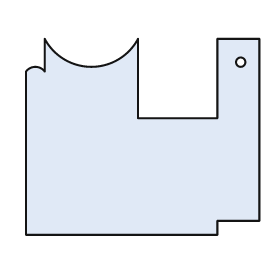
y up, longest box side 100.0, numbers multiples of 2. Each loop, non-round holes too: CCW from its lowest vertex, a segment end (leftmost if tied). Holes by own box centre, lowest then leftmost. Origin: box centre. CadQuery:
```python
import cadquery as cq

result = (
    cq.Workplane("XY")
    .moveTo(-50.0, -42.0)
    .lineTo(32.0, -42.0)
    .lineTo(32.0, -36.0)
    .lineTo(50.0, -36.0)
    .lineTo(50.0, 42.0)
    .lineTo(32.0, 42.0)
    .lineTo(32.0, 8.0)
    .lineTo(-2.0, 8.0)
    .lineTo(-2.0, 42.0)
    .threePointArc((-22.0, 30.0), (-42.0, 42.0))
    .lineTo(-42.0, 28.0)
    .threePointArc((-46.0, 30.0), (-50.0, 28.0))
    .close()
    .moveTo(42.0, 32.0)
    .circle(2.0)
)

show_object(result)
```